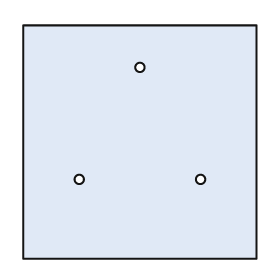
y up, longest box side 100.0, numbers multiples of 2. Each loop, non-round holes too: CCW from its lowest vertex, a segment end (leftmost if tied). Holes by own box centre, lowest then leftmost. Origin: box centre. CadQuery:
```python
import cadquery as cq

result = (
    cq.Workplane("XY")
    .moveTo(-50.0, -50.0)
    .lineTo(50.0, -50.0)
    .lineTo(50.0, 50.0)
    .lineTo(-50.0, 50.0)
    .close()
    .moveTo(-26.0, -16.0)
    .circle(2.0)
    .moveTo(26.0, -16.0)
    .circle(2.0)
    .moveTo(0.0, 32.0)
    .circle(2.0)
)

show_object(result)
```